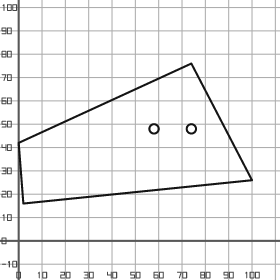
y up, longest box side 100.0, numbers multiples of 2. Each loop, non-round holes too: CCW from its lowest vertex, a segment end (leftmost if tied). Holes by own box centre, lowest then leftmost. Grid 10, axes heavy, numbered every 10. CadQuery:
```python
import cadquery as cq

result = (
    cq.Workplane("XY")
    .moveTo(2.0, 16.0)
    .lineTo(100.0, 26.0)
    .lineTo(74.0, 76.0)
    .lineTo(0.0, 42.0)
    .close()
    .moveTo(58.0, 48.0)
    .circle(2.0)
    .moveTo(74.0, 48.0)
    .circle(2.0)
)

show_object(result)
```